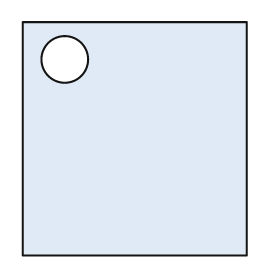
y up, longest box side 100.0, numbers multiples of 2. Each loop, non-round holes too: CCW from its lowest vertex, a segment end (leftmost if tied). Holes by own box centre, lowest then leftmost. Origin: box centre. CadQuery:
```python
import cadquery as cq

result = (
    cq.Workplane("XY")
    .moveTo(-48.0, -50.0)
    .lineTo(48.0, -50.0)
    .lineTo(48.0, 50.0)
    .lineTo(-48.0, 50.0)
    .close()
    .moveTo(-30.0, 34.0)
    .circle(10.0)
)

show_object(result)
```